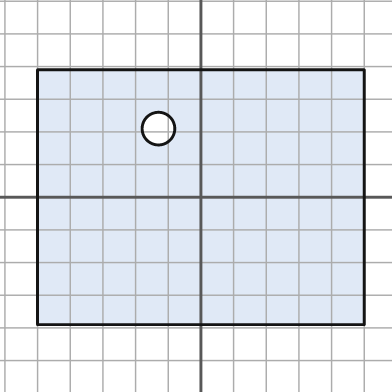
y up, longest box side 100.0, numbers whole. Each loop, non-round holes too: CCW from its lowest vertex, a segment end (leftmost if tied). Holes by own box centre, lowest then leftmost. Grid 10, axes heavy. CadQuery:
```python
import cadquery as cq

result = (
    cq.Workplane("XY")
    .moveTo(-50.0, -39.0)
    .lineTo(50.0, -39.0)
    .lineTo(50.0, 39.0)
    .lineTo(-50.0, 39.0)
    .close()
    .moveTo(-13.0, 21.0)
    .circle(5.0)
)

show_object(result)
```